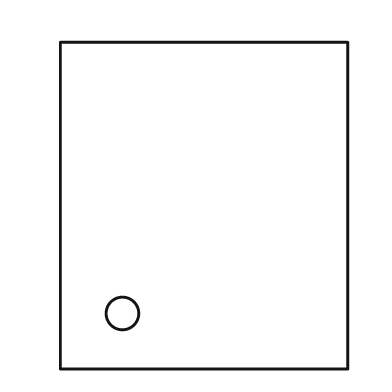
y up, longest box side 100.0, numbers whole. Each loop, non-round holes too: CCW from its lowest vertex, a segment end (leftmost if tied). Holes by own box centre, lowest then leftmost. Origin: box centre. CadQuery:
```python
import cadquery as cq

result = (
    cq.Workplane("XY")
    .moveTo(-44.0, -50.0)
    .lineTo(44.0, -50.0)
    .lineTo(44.0, 50.0)
    .lineTo(-44.0, 50.0)
    .close()
    .moveTo(-25.0, -33.0)
    .circle(5.0)
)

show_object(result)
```